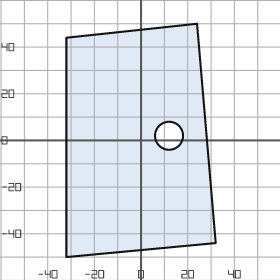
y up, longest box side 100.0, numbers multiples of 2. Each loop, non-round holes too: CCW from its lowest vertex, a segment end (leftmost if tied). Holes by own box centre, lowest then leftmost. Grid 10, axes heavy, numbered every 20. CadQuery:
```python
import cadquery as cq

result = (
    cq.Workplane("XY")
    .moveTo(-32.0, -50.0)
    .lineTo(32.0, -44.0)
    .lineTo(24.0, 50.0)
    .lineTo(-32.0, 44.0)
    .close()
    .moveTo(12.0, 2.0)
    .circle(6.0)
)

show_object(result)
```